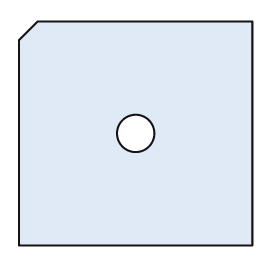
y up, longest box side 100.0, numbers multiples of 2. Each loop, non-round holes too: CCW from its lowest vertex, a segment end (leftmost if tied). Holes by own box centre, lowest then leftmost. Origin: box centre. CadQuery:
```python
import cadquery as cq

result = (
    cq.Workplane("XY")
    .moveTo(-50.0, -48.0)
    .lineTo(50.0, -48.0)
    .lineTo(50.0, 48.0)
    .lineTo(-42.0, 48.0)
    .lineTo(-50.0, 40.0)
    .close()
    .moveTo(0.0, 0.0)
    .circle(8.0)
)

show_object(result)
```